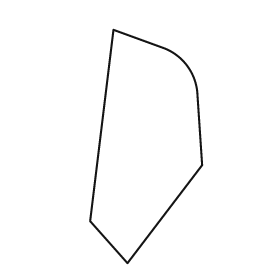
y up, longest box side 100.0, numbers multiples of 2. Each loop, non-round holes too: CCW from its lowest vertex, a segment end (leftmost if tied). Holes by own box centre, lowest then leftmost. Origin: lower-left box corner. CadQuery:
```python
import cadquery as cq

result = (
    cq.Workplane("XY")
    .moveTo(16.0, 0.0)
    .lineTo(48.0, 42.0)
    .lineTo(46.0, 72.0)
    .threePointArc((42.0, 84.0), (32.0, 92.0))
    .lineTo(10.0, 100.0)
    .lineTo(0.0, 18.0)
    .close()
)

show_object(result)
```